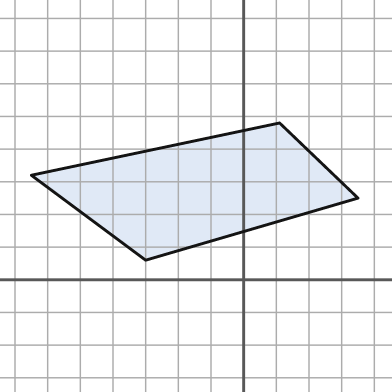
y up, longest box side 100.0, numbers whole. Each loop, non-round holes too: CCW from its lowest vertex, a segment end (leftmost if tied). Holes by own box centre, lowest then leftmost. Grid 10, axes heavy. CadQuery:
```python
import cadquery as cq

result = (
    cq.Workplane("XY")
    .moveTo(-30.0, 6.0)
    .lineTo(35.0, 25.0)
    .lineTo(11.0, 48.0)
    .lineTo(-65.0, 32.0)
    .close()
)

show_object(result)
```